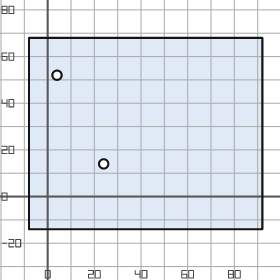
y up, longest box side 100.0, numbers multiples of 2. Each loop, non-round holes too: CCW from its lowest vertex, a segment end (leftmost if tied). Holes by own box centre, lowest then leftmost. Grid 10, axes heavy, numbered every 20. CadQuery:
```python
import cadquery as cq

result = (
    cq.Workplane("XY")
    .moveTo(-8.0, -14.0)
    .lineTo(92.0, -14.0)
    .lineTo(92.0, 68.0)
    .lineTo(-8.0, 68.0)
    .close()
    .moveTo(24.0, 14.0)
    .circle(2.0)
    .moveTo(4.0, 52.0)
    .circle(2.0)
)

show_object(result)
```